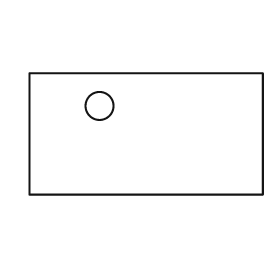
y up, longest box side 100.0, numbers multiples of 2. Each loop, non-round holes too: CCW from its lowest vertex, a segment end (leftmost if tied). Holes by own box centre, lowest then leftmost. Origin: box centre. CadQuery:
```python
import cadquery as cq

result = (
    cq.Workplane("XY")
    .moveTo(-50.0, -26.0)
    .lineTo(50.0, -26.0)
    .lineTo(50.0, 26.0)
    .lineTo(-50.0, 26.0)
    .close()
    .moveTo(-20.0, 12.0)
    .circle(6.0)
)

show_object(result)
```